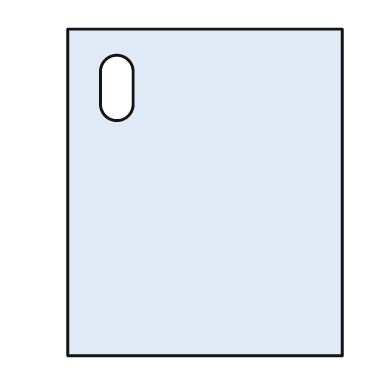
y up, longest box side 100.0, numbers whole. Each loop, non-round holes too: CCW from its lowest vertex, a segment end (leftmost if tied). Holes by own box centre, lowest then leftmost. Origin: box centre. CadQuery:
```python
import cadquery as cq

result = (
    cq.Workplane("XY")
    .moveTo(-42.0, -50.0)
    .lineTo(42.0, -50.0)
    .lineTo(42.0, 50.0)
    .lineTo(-42.0, 50.0)
    .close()
    .moveTo(-32.0, 27.0)
    .threePointArc((-27.0, 22.0), (-22.0, 27.0))
    .lineTo(-22.0, 37.0)
    .threePointArc((-27.0, 42.0), (-32.0, 37.0))
    .close()
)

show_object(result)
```